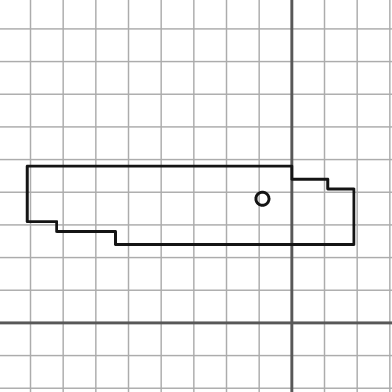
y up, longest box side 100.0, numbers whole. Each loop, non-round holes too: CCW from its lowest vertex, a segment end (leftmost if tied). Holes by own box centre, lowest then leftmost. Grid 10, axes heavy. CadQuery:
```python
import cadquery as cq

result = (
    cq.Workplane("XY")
    .moveTo(-54.0, 24.0)
    .lineTo(19.0, 24.0)
    .lineTo(19.0, 41.0)
    .lineTo(11.0, 41.0)
    .lineTo(11.0, 44.0)
    .lineTo(0.0, 44.0)
    .lineTo(0.0, 48.0)
    .lineTo(-81.0, 48.0)
    .lineTo(-81.0, 31.0)
    .lineTo(-72.0, 31.0)
    .lineTo(-72.0, 28.0)
    .lineTo(-54.0, 28.0)
    .close()
    .moveTo(-9.0, 38.0)
    .circle(2.0)
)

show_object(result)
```